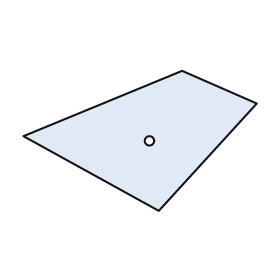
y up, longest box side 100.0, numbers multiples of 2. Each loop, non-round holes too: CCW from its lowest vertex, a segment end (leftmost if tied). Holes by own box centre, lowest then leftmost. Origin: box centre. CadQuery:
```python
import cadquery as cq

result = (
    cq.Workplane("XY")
    .moveTo(8.0, -30.0)
    .lineTo(50.0, 16.0)
    .lineTo(18.0, 30.0)
    .lineTo(-50.0, 2.0)
    .close()
    .moveTo(4.0, 0.0)
    .circle(2.0)
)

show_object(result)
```